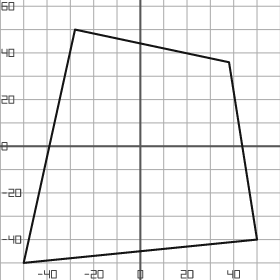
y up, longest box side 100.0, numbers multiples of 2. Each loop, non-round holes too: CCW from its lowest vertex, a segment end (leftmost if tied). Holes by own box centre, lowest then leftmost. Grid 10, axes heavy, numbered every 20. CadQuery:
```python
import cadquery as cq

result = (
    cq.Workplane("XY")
    .moveTo(-50.0, -50.0)
    .lineTo(50.0, -40.0)
    .lineTo(38.0, 36.0)
    .lineTo(-28.0, 50.0)
    .close()
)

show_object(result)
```